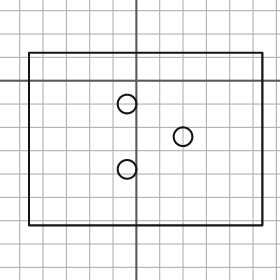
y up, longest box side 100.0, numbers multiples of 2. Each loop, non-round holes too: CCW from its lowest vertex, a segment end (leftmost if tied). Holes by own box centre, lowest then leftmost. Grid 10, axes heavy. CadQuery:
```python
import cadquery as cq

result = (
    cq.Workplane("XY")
    .moveTo(-46.0, -62.0)
    .lineTo(54.0, -62.0)
    .lineTo(54.0, 12.0)
    .lineTo(-46.0, 12.0)
    .close()
    .moveTo(-4.0, -38.0)
    .circle(4.0)
    .moveTo(20.0, -24.0)
    .circle(4.0)
    .moveTo(-4.0, -10.0)
    .circle(4.0)
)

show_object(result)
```